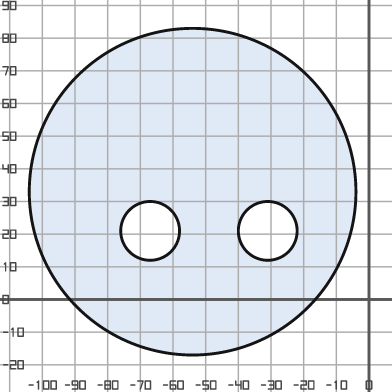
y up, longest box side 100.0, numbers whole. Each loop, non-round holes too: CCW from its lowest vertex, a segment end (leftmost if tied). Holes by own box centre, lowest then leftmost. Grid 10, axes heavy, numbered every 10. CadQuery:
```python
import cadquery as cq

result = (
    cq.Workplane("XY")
    .moveTo(-54.0, 33.0)
    .circle(50.0)
    .moveTo(-67.0, 21.0)
    .circle(9.0)
    .moveTo(-31.0, 21.0)
    .circle(9.0)
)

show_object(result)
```